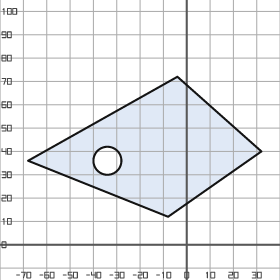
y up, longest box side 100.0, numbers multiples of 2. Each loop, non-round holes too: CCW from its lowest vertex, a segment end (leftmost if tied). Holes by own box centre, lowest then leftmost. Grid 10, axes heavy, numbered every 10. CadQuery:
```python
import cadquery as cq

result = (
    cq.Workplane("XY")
    .moveTo(-8.0, 12.0)
    .lineTo(32.0, 40.0)
    .lineTo(-4.0, 72.0)
    .lineTo(-68.0, 36.0)
    .close()
    .moveTo(-34.0, 36.0)
    .circle(6.0)
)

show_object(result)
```